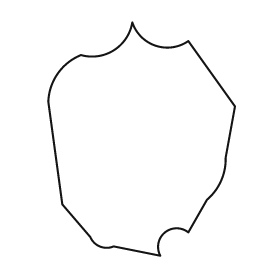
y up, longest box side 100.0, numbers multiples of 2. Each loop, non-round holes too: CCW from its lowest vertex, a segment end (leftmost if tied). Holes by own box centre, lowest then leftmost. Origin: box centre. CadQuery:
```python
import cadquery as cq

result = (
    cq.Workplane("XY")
    .moveTo(8.0, -50.0)
    .threePointArc((10.0, -40.0), (20.0, -40.0))
    .lineTo(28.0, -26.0)
    .threePointArc((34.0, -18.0), (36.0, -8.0))
    .lineTo(40.0, 14.0)
    .lineTo(20.0, 42.0)
    .threePointArc((6.0, 40.0), (-4.0, 50.0))
    .threePointArc((-12.0, 38.0), (-26.0, 36.0))
    .threePointArc((-36.0, 28.0), (-40.0, 16.0))
    .lineTo(-34.0, -28.0)
    .lineTo(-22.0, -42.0)
    .threePointArc((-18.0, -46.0), (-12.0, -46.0))
    .close()
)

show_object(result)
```